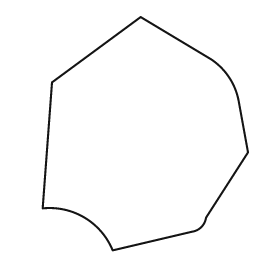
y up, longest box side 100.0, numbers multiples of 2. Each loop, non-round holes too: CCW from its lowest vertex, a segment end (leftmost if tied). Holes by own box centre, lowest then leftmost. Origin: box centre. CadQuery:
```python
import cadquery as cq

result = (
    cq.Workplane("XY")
    .moveTo(-14.0, -50.0)
    .lineTo(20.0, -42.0)
    .threePointArc((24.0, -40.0), (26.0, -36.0))
    .lineTo(44.0, -8.0)
    .lineTo(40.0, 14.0)
    .threePointArc((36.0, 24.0), (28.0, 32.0))
    .lineTo(-2.0, 50.0)
    .lineTo(-40.0, 22.0)
    .lineTo(-44.0, -32.0)
    .threePointArc((-26.0, -36.0), (-14.0, -50.0))
    .close()
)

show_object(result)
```